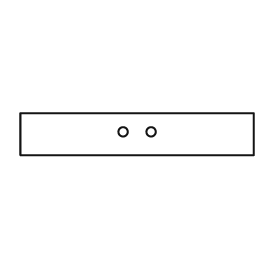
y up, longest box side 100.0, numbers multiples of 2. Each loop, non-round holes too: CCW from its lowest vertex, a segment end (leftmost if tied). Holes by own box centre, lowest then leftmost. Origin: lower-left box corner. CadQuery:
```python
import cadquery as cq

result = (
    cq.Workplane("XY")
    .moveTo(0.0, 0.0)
    .lineTo(100.0, 0.0)
    .lineTo(100.0, 18.0)
    .lineTo(0.0, 18.0)
    .close()
    .moveTo(44.0, 10.0)
    .circle(2.0)
    .moveTo(56.0, 10.0)
    .circle(2.0)
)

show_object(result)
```